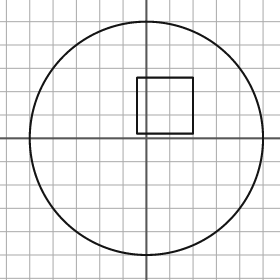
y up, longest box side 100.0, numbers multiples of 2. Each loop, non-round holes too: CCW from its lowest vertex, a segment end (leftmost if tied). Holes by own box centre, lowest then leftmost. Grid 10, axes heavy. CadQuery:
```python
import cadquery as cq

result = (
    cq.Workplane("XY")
    .moveTo(0.0, 0.0)
    .circle(50.0)
    .moveTo(-4.0, 2.0)
    .lineTo(20.0, 2.0)
    .lineTo(20.0, 26.0)
    .lineTo(-4.0, 26.0)
    .close()
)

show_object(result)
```